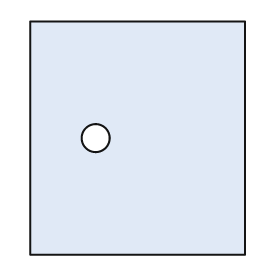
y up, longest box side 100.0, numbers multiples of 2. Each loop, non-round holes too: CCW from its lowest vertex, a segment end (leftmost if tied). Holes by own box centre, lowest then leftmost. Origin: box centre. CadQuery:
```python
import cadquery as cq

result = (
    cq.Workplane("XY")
    .moveTo(-46.0, -50.0)
    .lineTo(46.0, -50.0)
    .lineTo(46.0, 50.0)
    .lineTo(-46.0, 50.0)
    .close()
    .moveTo(-18.0, 0.0)
    .circle(6.0)
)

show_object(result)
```